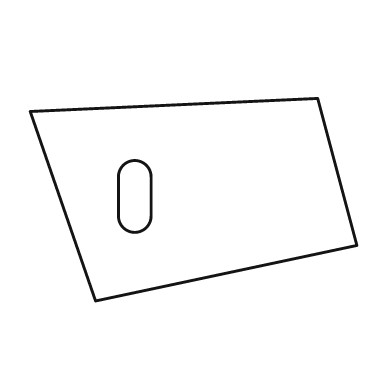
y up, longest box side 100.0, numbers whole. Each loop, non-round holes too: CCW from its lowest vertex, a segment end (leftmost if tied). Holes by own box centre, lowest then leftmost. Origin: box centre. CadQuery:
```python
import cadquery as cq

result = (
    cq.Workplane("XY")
    .moveTo(-30.0, -31.0)
    .lineTo(50.0, -14.0)
    .lineTo(38.0, 31.0)
    .lineTo(-50.0, 27.0)
    .close()
    .moveTo(-23.0, -5.0)
    .threePointArc((-18.0, -10.0), (-13.0, -5.0))
    .lineTo(-13.0, 7.0)
    .threePointArc((-18.0, 12.0), (-23.0, 7.0))
    .close()
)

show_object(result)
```